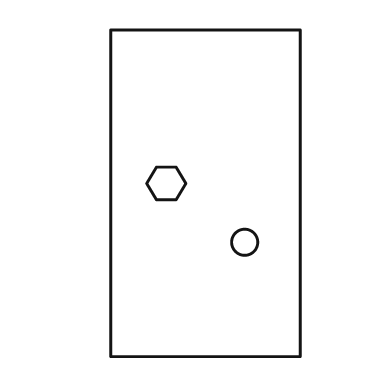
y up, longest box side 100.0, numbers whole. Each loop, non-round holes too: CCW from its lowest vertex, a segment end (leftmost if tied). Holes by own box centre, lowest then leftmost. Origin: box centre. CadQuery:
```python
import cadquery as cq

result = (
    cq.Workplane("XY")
    .moveTo(-29.0, -50.0)
    .lineTo(29.0, -50.0)
    .lineTo(29.0, 50.0)
    .lineTo(-29.0, 50.0)
    .close()
    .moveTo(12.0, -15.0)
    .circle(4.0)
    .moveTo(-15.0, -2.0)
    .lineTo(-9.0, -2.0)
    .lineTo(-6.0, 3.0)
    .lineTo(-9.0, 8.0)
    .lineTo(-15.0, 8.0)
    .lineTo(-18.0, 3.0)
    .close()
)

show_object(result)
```